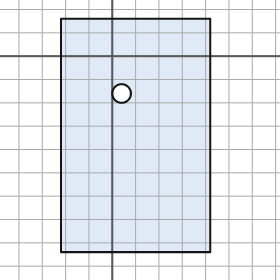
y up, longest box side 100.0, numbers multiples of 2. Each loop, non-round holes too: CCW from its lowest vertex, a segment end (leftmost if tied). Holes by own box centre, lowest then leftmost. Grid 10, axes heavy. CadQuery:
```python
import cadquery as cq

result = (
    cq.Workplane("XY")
    .moveTo(-22.0, -84.0)
    .lineTo(42.0, -84.0)
    .lineTo(42.0, 16.0)
    .lineTo(-22.0, 16.0)
    .close()
    .moveTo(4.0, -16.0)
    .circle(4.0)
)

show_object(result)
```